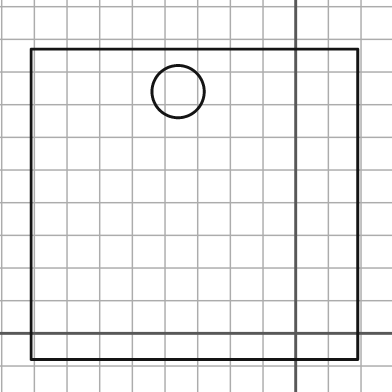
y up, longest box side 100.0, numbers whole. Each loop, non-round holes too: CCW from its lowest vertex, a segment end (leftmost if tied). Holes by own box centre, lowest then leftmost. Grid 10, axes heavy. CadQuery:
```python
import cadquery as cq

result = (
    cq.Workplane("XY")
    .moveTo(-81.0, -8.0)
    .lineTo(19.0, -8.0)
    .lineTo(19.0, 87.0)
    .lineTo(-81.0, 87.0)
    .close()
    .moveTo(-36.0, 74.0)
    .circle(8.0)
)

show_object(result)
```